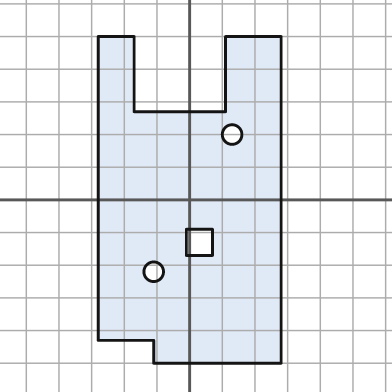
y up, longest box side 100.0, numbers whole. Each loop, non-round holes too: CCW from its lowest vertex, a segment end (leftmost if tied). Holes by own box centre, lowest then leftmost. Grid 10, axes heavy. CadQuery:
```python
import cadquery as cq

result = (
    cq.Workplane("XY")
    .moveTo(-11.0, -50.0)
    .lineTo(28.0, -50.0)
    .lineTo(28.0, 50.0)
    .lineTo(11.0, 50.0)
    .lineTo(11.0, 27.0)
    .lineTo(-17.0, 27.0)
    .lineTo(-17.0, 50.0)
    .lineTo(-28.0, 50.0)
    .lineTo(-28.0, -43.0)
    .lineTo(-11.0, -43.0)
    .close()
    .moveTo(-11.0, -22.0)
    .circle(3.0)
    .moveTo(-1.0, -17.0)
    .lineTo(7.0, -17.0)
    .lineTo(7.0, -9.0)
    .lineTo(-1.0, -9.0)
    .close()
    .moveTo(13.0, 20.0)
    .circle(3.0)
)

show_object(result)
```